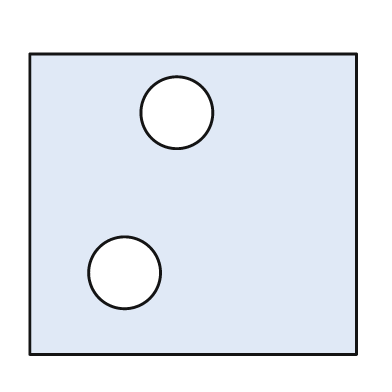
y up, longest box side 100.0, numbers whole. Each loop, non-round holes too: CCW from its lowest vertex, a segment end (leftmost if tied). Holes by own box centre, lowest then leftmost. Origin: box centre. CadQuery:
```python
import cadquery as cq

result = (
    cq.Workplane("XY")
    .moveTo(-50.0, -46.0)
    .lineTo(50.0, -46.0)
    .lineTo(50.0, 46.0)
    .lineTo(-50.0, 46.0)
    .close()
    .moveTo(-21.0, -21.0)
    .circle(11.0)
    .moveTo(-5.0, 28.0)
    .circle(11.0)
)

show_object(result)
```